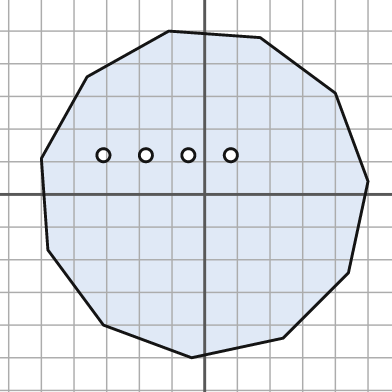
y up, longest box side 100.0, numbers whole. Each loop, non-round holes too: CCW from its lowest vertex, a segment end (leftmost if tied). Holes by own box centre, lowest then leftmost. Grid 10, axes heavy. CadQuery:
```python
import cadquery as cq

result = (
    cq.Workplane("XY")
    .moveTo(-4.0, -50.0)
    .lineTo(24.0, -44.0)
    .lineTo(44.0, -24.0)
    .lineTo(50.0, 4.0)
    .lineTo(40.0, 31.0)
    .lineTo(17.0, 48.0)
    .lineTo(-11.0, 50.0)
    .lineTo(-36.0, 36.0)
    .lineTo(-50.0, 11.0)
    .lineTo(-48.0, -17.0)
    .lineTo(-31.0, -40.0)
    .close()
    .moveTo(-31.0, 12.0)
    .circle(2.0)
    .moveTo(-18.0, 12.0)
    .circle(2.0)
    .moveTo(-5.0, 12.0)
    .circle(2.0)
    .moveTo(8.0, 12.0)
    .circle(2.0)
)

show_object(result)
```